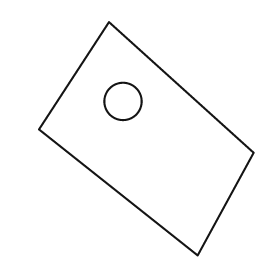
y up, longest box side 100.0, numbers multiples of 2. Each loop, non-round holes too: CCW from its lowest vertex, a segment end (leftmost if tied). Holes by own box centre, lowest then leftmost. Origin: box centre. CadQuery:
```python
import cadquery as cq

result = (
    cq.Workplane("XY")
    .moveTo(22.0, -50.0)
    .lineTo(46.0, -6.0)
    .lineTo(-16.0, 50.0)
    .lineTo(-46.0, 4.0)
    .close()
    .moveTo(-10.0, 16.0)
    .circle(8.0)
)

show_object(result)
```